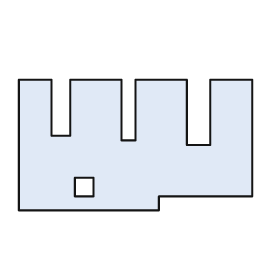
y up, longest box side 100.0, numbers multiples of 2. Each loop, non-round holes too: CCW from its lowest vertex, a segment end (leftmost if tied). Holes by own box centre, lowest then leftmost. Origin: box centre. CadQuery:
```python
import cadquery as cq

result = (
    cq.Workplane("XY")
    .moveTo(-50.0, -28.0)
    .lineTo(10.0, -28.0)
    .lineTo(10.0, -22.0)
    .lineTo(50.0, -22.0)
    .lineTo(50.0, 28.0)
    .lineTo(32.0, 28.0)
    .lineTo(32.0, 0.0)
    .lineTo(22.0, 0.0)
    .lineTo(22.0, 28.0)
    .lineTo(0.0, 28.0)
    .lineTo(0.0, 2.0)
    .lineTo(-6.0, 2.0)
    .lineTo(-6.0, 28.0)
    .lineTo(-28.0, 28.0)
    .lineTo(-28.0, 4.0)
    .lineTo(-36.0, 4.0)
    .lineTo(-36.0, 28.0)
    .lineTo(-50.0, 28.0)
    .close()
    .moveTo(-26.0, -22.0)
    .lineTo(-18.0, -22.0)
    .lineTo(-18.0, -14.0)
    .lineTo(-26.0, -14.0)
    .close()
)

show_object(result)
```